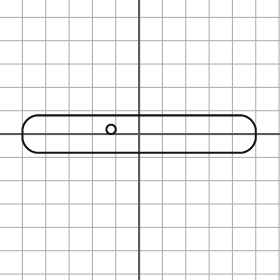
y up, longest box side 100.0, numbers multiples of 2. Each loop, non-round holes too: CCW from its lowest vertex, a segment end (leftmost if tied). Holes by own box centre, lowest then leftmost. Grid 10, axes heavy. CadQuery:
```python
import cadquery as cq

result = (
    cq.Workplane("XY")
    .moveTo(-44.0, -8.0)
    .lineTo(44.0, -8.0)
    .threePointArc((48.0, -6.0), (50.0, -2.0))
    .lineTo(50.0, 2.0)
    .threePointArc((48.0, 6.0), (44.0, 8.0))
    .lineTo(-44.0, 8.0)
    .threePointArc((-48.0, 6.0), (-50.0, 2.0))
    .lineTo(-50.0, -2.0)
    .threePointArc((-48.0, -6.0), (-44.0, -8.0))
    .close()
    .moveTo(-12.0, 2.0)
    .circle(2.0)
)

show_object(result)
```